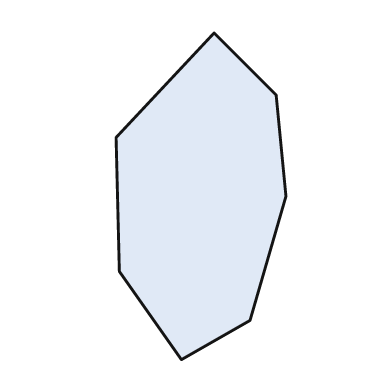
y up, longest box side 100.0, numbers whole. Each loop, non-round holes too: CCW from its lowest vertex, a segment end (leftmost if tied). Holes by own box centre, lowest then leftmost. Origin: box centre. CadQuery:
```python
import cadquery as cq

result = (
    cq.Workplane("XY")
    .moveTo(-6.0, -50.0)
    .lineTo(15.0, -38.0)
    .lineTo(26.0, 0.0)
    .lineTo(23.0, 31.0)
    .lineTo(4.0, 50.0)
    .lineTo(-26.0, 18.0)
    .lineTo(-25.0, -23.0)
    .close()
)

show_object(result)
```